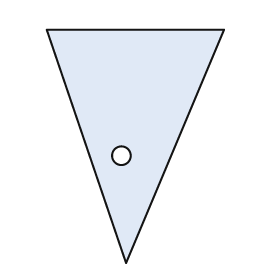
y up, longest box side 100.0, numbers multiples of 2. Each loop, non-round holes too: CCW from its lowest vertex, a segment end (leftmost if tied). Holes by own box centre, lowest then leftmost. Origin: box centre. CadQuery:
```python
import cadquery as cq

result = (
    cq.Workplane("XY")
    .moveTo(-4.0, -50.0)
    .lineTo(38.0, 50.0)
    .lineTo(-38.0, 50.0)
    .close()
    .moveTo(-6.0, -4.0)
    .circle(4.0)
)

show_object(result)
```